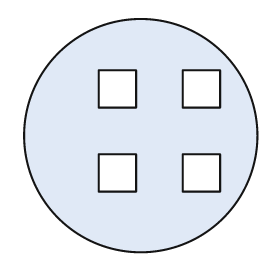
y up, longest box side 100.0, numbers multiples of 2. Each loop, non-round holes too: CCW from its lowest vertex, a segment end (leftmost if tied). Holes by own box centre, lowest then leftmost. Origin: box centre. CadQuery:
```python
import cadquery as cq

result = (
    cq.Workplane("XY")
    .moveTo(0.0, 0.0)
    .circle(50.0)
    .moveTo(-18.0, -24.0)
    .lineTo(-2.0, -24.0)
    .lineTo(-2.0, -8.0)
    .lineTo(-18.0, -8.0)
    .close()
    .moveTo(18.0, -24.0)
    .lineTo(34.0, -24.0)
    .lineTo(34.0, -8.0)
    .lineTo(18.0, -8.0)
    .close()
    .moveTo(-18.0, 12.0)
    .lineTo(-2.0, 12.0)
    .lineTo(-2.0, 28.0)
    .lineTo(-18.0, 28.0)
    .close()
    .moveTo(18.0, 12.0)
    .lineTo(34.0, 12.0)
    .lineTo(34.0, 28.0)
    .lineTo(18.0, 28.0)
    .close()
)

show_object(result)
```